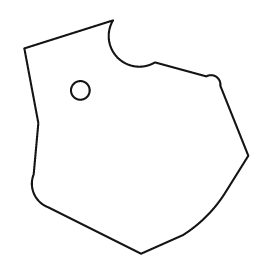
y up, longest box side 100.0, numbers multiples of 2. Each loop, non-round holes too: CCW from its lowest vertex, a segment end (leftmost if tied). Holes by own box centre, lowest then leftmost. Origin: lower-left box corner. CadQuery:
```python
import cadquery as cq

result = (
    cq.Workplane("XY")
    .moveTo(50.0, 0.0)
    .lineTo(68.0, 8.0)
    .threePointArc((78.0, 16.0), (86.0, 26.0))
    .lineTo(96.0, 42.0)
    .lineTo(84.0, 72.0)
    .threePointArc((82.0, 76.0), (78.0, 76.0))
    .lineTo(56.0, 82.0)
    .threePointArc((40.0, 84.0), (38.0, 100.0))
    .lineTo(0.0, 88.0)
    .lineTo(6.0, 56.0)
    .lineTo(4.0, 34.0)
    .threePointArc((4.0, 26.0), (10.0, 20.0))
    .close()
    .moveTo(24.0, 70.0)
    .circle(4.0)
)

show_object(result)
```